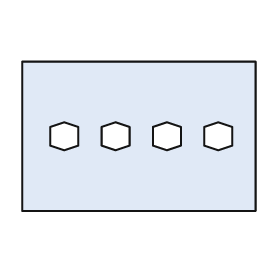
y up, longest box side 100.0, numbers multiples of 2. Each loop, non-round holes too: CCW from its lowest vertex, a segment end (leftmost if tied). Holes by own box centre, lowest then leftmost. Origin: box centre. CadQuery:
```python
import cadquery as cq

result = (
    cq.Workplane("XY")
    .moveTo(-50.0, -32.0)
    .lineTo(50.0, -32.0)
    .lineTo(50.0, 32.0)
    .lineTo(-50.0, 32.0)
    .close()
    .moveTo(-32.0, -6.0)
    .lineTo(-26.0, -4.0)
    .lineTo(-26.0, 4.0)
    .lineTo(-32.0, 6.0)
    .lineTo(-38.0, 4.0)
    .lineTo(-38.0, -4.0)
    .close()
    .moveTo(-10.0, -6.0)
    .lineTo(-4.0, -4.0)
    .lineTo(-4.0, 4.0)
    .lineTo(-10.0, 6.0)
    .lineTo(-16.0, 4.0)
    .lineTo(-16.0, -4.0)
    .close()
    .moveTo(12.0, -6.0)
    .lineTo(18.0, -4.0)
    .lineTo(18.0, 4.0)
    .lineTo(12.0, 6.0)
    .lineTo(6.0, 4.0)
    .lineTo(6.0, -4.0)
    .close()
    .moveTo(34.0, -6.0)
    .lineTo(40.0, -4.0)
    .lineTo(40.0, 4.0)
    .lineTo(34.0, 6.0)
    .lineTo(28.0, 4.0)
    .lineTo(28.0, -4.0)
    .close()
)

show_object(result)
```